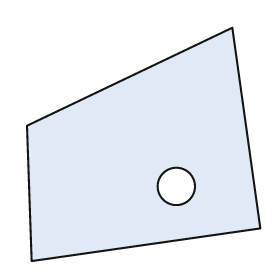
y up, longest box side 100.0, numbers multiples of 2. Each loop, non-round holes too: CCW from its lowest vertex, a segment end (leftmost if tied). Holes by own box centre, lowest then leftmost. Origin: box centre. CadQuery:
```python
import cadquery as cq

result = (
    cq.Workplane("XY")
    .moveTo(-48.0, -50.0)
    .lineTo(50.0, -36.0)
    .lineTo(38.0, 50.0)
    .lineTo(-50.0, 8.0)
    .close()
    .moveTo(14.0, -18.0)
    .circle(8.0)
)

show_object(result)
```